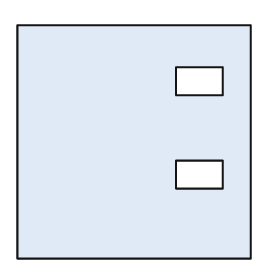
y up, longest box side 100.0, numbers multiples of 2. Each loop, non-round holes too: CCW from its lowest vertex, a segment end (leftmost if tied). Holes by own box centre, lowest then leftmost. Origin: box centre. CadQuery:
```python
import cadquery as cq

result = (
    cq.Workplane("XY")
    .moveTo(-50.0, -50.0)
    .lineTo(50.0, -50.0)
    .lineTo(50.0, 50.0)
    .lineTo(-50.0, 50.0)
    .close()
    .moveTo(18.0, -20.0)
    .lineTo(38.0, -20.0)
    .lineTo(38.0, -8.0)
    .lineTo(18.0, -8.0)
    .close()
    .moveTo(18.0, 20.0)
    .lineTo(38.0, 20.0)
    .lineTo(38.0, 32.0)
    .lineTo(18.0, 32.0)
    .close()
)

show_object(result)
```